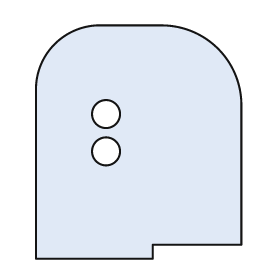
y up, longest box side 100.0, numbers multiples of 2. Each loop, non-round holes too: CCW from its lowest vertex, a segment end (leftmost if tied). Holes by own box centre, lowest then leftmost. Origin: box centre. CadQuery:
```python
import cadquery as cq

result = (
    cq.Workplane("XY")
    .moveTo(-44.0, -50.0)
    .lineTo(6.0, -50.0)
    .lineTo(6.0, -44.0)
    .lineTo(44.0, -44.0)
    .lineTo(44.0, 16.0)
    .threePointArc((34.0, 40.0), (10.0, 50.0))
    .lineTo(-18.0, 50.0)
    .threePointArc((-36.0, 42.0), (-44.0, 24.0))
    .close()
    .moveTo(-14.0, -4.0)
    .circle(6.0)
    .moveTo(-14.0, 12.0)
    .circle(6.0)
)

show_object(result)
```